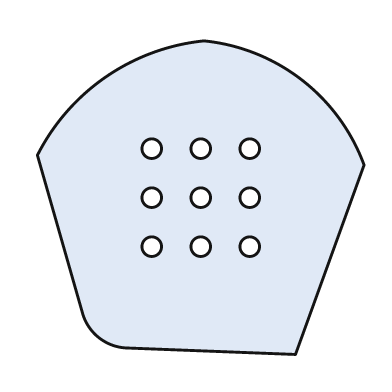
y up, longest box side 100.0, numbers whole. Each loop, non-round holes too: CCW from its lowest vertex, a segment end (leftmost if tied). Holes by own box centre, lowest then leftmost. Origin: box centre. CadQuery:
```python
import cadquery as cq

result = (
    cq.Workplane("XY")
    .moveTo(29.0, -48.0)
    .lineTo(50.0, 10.0)
    .threePointArc((31.0, 36.0), (1.0, 48.0))
    .threePointArc((-29.0, 37.0), (-50.0, 13.0))
    .lineTo(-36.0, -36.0)
    .threePointArc((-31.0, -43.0), (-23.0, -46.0))
    .close()
    .moveTo(-15.0, -15.0)
    .circle(3.0)
    .moveTo(0.0, -15.0)
    .circle(3.0)
    .moveTo(15.0, -15.0)
    .circle(3.0)
    .moveTo(-15.0, 0.0)
    .circle(3.0)
    .moveTo(0.0, 0.0)
    .circle(3.0)
    .moveTo(15.0, 0.0)
    .circle(3.0)
    .moveTo(-15.0, 15.0)
    .circle(3.0)
    .moveTo(0.0, 15.0)
    .circle(3.0)
    .moveTo(15.0, 15.0)
    .circle(3.0)
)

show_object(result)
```